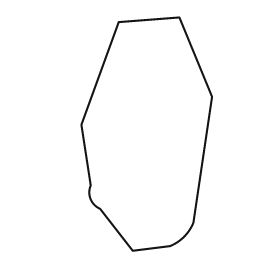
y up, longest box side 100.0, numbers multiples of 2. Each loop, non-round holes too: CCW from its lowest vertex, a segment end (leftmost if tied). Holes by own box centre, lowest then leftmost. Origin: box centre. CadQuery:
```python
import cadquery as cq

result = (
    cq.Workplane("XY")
    .moveTo(-6.0, -50.0)
    .lineTo(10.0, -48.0)
    .threePointArc((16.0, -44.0), (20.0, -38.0))
    .lineTo(28.0, 16.0)
    .lineTo(14.0, 50.0)
    .lineTo(-12.0, 48.0)
    .lineTo(-28.0, 4.0)
    .lineTo(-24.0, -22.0)
    .threePointArc((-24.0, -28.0), (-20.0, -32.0))
    .close()
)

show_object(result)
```